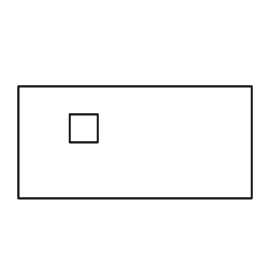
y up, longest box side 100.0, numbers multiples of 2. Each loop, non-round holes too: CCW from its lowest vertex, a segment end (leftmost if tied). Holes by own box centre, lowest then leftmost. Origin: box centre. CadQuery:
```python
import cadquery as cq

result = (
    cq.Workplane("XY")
    .moveTo(-50.0, -24.0)
    .lineTo(50.0, -24.0)
    .lineTo(50.0, 24.0)
    .lineTo(-50.0, 24.0)
    .close()
    .moveTo(-28.0, 0.0)
    .lineTo(-16.0, 0.0)
    .lineTo(-16.0, 12.0)
    .lineTo(-28.0, 12.0)
    .close()
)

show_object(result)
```